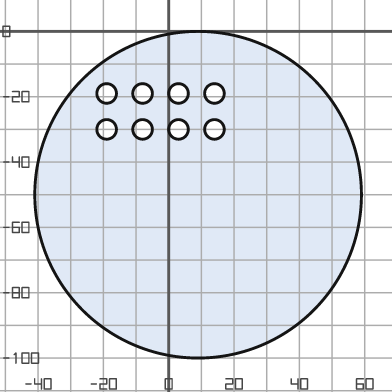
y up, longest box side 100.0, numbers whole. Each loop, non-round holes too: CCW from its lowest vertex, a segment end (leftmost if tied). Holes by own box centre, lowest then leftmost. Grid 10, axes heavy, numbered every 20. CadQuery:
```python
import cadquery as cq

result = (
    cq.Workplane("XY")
    .moveTo(9.0, -50.0)
    .circle(50.0)
    .moveTo(-19.0, -30.0)
    .circle(3.0)
    .moveTo(-8.0, -30.0)
    .circle(3.0)
    .moveTo(3.0, -30.0)
    .circle(3.0)
    .moveTo(14.0, -30.0)
    .circle(3.0)
    .moveTo(-19.0, -19.0)
    .circle(3.0)
    .moveTo(-8.0, -19.0)
    .circle(3.0)
    .moveTo(3.0, -19.0)
    .circle(3.0)
    .moveTo(14.0, -19.0)
    .circle(3.0)
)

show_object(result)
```